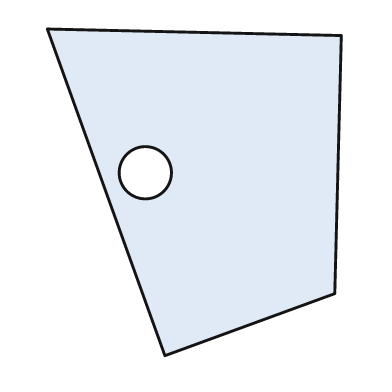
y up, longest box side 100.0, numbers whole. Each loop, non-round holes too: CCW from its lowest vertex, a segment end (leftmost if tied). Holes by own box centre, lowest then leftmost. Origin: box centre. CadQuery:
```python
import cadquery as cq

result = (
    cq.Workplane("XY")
    .moveTo(-9.0, -50.0)
    .lineTo(43.0, -31.0)
    .lineTo(45.0, 48.0)
    .lineTo(-45.0, 50.0)
    .close()
    .moveTo(-15.0, 6.0)
    .circle(8.0)
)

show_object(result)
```